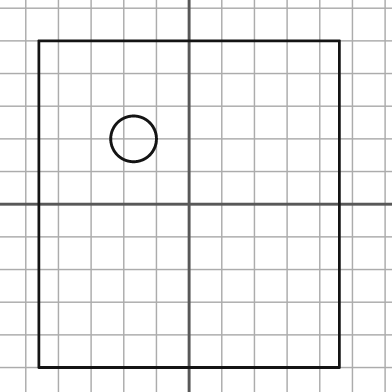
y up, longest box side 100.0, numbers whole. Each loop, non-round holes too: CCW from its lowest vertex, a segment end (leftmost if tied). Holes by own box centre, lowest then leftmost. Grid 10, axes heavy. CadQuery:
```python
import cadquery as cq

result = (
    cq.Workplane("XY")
    .moveTo(-46.0, -50.0)
    .lineTo(46.0, -50.0)
    .lineTo(46.0, 50.0)
    .lineTo(-46.0, 50.0)
    .close()
    .moveTo(-17.0, 20.0)
    .circle(7.0)
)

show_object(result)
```